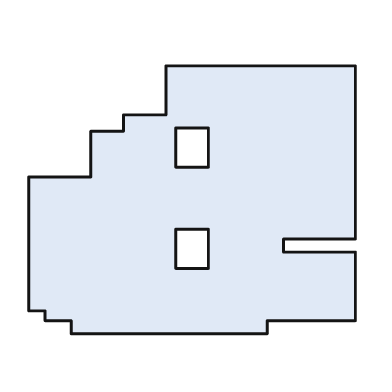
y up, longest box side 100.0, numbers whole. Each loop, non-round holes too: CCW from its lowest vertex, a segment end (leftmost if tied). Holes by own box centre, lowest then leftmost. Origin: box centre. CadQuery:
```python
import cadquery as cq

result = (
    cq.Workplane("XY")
    .moveTo(-37.0, -41.0)
    .lineTo(23.0, -41.0)
    .lineTo(23.0, -37.0)
    .lineTo(50.0, -37.0)
    .lineTo(50.0, -16.0)
    .lineTo(28.0, -16.0)
    .lineTo(28.0, -12.0)
    .lineTo(50.0, -12.0)
    .lineTo(50.0, 41.0)
    .lineTo(-8.0, 41.0)
    .lineTo(-8.0, 26.0)
    .lineTo(-21.0, 26.0)
    .lineTo(-21.0, 21.0)
    .lineTo(-31.0, 21.0)
    .lineTo(-31.0, 7.0)
    .lineTo(-50.0, 7.0)
    .lineTo(-50.0, -34.0)
    .lineTo(-45.0, -34.0)
    .lineTo(-45.0, -37.0)
    .lineTo(-37.0, -37.0)
    .close()
    .moveTo(-5.0, -21.0)
    .lineTo(5.0, -21.0)
    .lineTo(5.0, -9.0)
    .lineTo(-5.0, -9.0)
    .close()
    .moveTo(-5.0, 10.0)
    .lineTo(5.0, 10.0)
    .lineTo(5.0, 22.0)
    .lineTo(-5.0, 22.0)
    .close()
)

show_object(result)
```